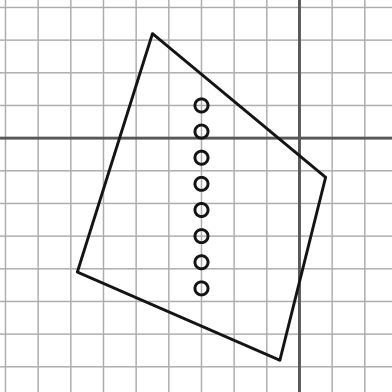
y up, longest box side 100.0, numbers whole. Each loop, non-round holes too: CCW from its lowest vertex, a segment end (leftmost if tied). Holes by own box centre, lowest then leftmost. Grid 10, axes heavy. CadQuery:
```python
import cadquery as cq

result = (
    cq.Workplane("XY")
    .moveTo(-6.0, -68.0)
    .lineTo(8.0, -12.0)
    .lineTo(-45.0, 32.0)
    .lineTo(-68.0, -41.0)
    .close()
    .moveTo(-30.0, -46.0)
    .circle(2.0)
    .moveTo(-30.0, -38.0)
    .circle(2.0)
    .moveTo(-30.0, -30.0)
    .circle(2.0)
    .moveTo(-30.0, -22.0)
    .circle(2.0)
    .moveTo(-30.0, -14.0)
    .circle(2.0)
    .moveTo(-30.0, -6.0)
    .circle(2.0)
    .moveTo(-30.0, 2.0)
    .circle(2.0)
    .moveTo(-30.0, 10.0)
    .circle(2.0)
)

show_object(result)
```